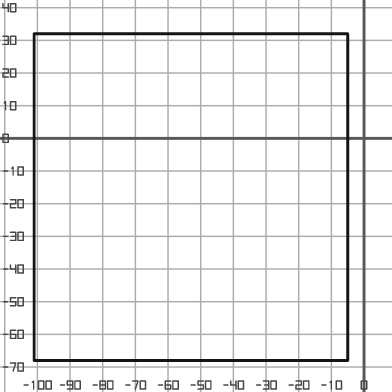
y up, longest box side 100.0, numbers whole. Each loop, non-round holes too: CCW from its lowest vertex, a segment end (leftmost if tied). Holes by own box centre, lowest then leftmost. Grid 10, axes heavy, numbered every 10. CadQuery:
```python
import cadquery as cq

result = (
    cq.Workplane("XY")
    .moveTo(-101.0, -68.0)
    .lineTo(-5.0, -68.0)
    .lineTo(-5.0, 32.0)
    .lineTo(-101.0, 32.0)
    .close()
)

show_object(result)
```